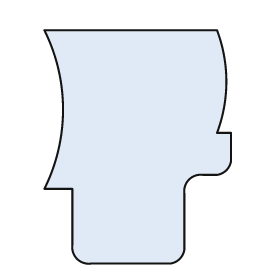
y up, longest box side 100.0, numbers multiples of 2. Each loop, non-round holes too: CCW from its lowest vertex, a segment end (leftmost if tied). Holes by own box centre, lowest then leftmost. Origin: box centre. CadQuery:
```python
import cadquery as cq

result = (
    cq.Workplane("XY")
    .moveTo(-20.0, -50.0)
    .lineTo(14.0, -50.0)
    .threePointArc((18.0, -48.0), (20.0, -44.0))
    .lineTo(20.0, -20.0)
    .threePointArc((22.0, -14.0), (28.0, -12.0))
    .lineTo(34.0, -12.0)
    .threePointArc((38.0, -10.0), (40.0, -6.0))
    .lineTo(40.0, 6.0)
    .lineTo(34.0, 6.0)
    .threePointArc((38.0, 28.0), (34.0, 50.0))
    .lineTo(-40.0, 50.0)
    .threePointArc((-32.0, 16.0), (-40.0, -18.0))
    .lineTo(-28.0, -18.0)
    .lineTo(-28.0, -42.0)
    .threePointArc((-26.0, -48.0), (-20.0, -50.0))
    .close()
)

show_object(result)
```